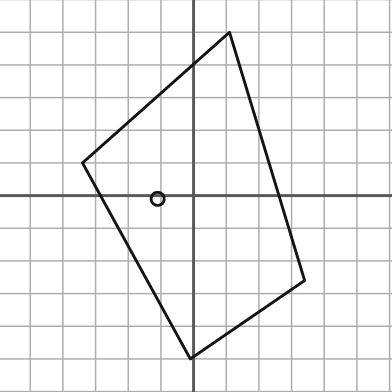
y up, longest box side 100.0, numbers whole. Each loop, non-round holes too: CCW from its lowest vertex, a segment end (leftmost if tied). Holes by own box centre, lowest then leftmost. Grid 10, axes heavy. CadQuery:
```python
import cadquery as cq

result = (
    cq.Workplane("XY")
    .moveTo(-1.0, -50.0)
    .lineTo(34.0, -26.0)
    .lineTo(11.0, 50.0)
    .lineTo(-34.0, 10.0)
    .close()
    .moveTo(-11.0, -1.0)
    .circle(2.0)
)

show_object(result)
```